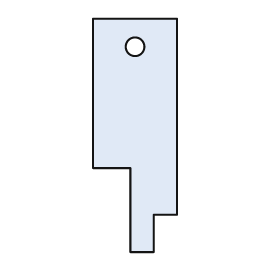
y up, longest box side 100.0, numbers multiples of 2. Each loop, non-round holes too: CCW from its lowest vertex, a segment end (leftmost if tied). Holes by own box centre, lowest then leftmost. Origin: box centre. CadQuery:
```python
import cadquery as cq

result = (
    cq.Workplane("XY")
    .moveTo(-2.0, -50.0)
    .lineTo(8.0, -50.0)
    .lineTo(8.0, -34.0)
    .lineTo(18.0, -34.0)
    .lineTo(18.0, 50.0)
    .lineTo(-18.0, 50.0)
    .lineTo(-18.0, -14.0)
    .lineTo(-2.0, -14.0)
    .close()
    .moveTo(0.0, 38.0)
    .circle(4.0)
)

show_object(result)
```